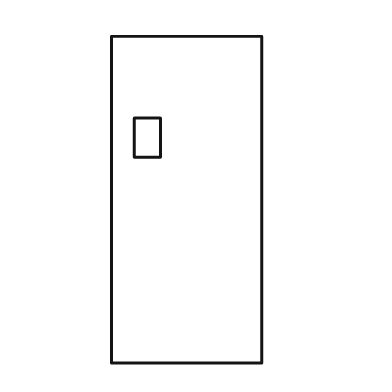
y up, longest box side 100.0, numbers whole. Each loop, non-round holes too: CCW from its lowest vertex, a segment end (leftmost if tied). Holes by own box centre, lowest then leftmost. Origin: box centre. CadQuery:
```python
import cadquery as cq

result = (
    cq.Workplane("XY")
    .moveTo(-23.0, -50.0)
    .lineTo(23.0, -50.0)
    .lineTo(23.0, 50.0)
    .lineTo(-23.0, 50.0)
    .close()
    .moveTo(-16.0, 13.0)
    .lineTo(-8.0, 13.0)
    .lineTo(-8.0, 25.0)
    .lineTo(-16.0, 25.0)
    .close()
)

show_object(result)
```